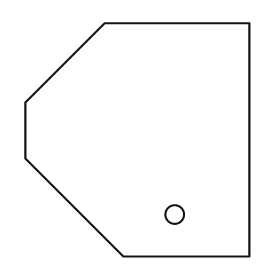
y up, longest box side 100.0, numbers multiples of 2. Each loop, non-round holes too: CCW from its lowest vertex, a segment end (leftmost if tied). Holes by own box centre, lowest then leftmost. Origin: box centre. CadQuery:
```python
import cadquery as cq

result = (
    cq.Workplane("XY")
    .moveTo(-6.0, -50.0)
    .lineTo(48.0, -50.0)
    .lineTo(48.0, 50.0)
    .lineTo(-14.0, 50.0)
    .lineTo(-48.0, 16.0)
    .lineTo(-48.0, -8.0)
    .close()
    .moveTo(16.0, -32.0)
    .circle(4.0)
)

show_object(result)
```